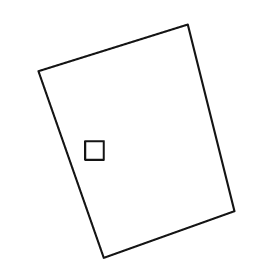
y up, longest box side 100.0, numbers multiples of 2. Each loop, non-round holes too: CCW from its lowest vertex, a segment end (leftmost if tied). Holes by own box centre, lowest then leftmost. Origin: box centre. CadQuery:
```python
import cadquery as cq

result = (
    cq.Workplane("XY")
    .moveTo(-14.0, -50.0)
    .lineTo(42.0, -30.0)
    .lineTo(22.0, 50.0)
    .lineTo(-42.0, 30.0)
    .close()
    .moveTo(-22.0, -8.0)
    .lineTo(-14.0, -8.0)
    .lineTo(-14.0, 0.0)
    .lineTo(-22.0, 0.0)
    .close()
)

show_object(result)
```